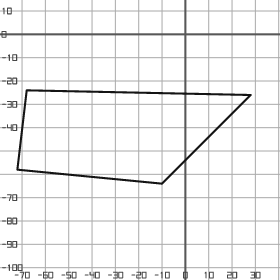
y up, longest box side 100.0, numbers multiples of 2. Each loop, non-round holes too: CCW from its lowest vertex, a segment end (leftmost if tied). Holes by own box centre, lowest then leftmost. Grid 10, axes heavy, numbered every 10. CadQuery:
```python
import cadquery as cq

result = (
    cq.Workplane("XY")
    .moveTo(-10.0, -64.0)
    .lineTo(28.0, -26.0)
    .lineTo(-68.0, -24.0)
    .lineTo(-72.0, -58.0)
    .close()
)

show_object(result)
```